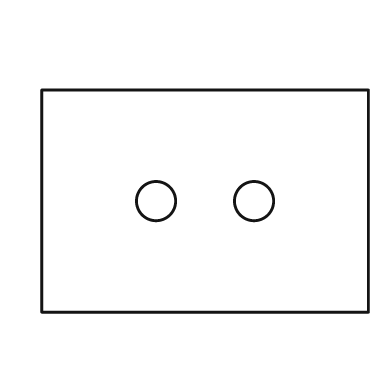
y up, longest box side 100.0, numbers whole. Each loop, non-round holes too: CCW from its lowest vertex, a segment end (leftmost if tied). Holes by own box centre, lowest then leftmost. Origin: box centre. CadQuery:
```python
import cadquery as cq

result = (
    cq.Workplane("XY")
    .moveTo(-50.0, -34.0)
    .lineTo(50.0, -34.0)
    .lineTo(50.0, 34.0)
    .lineTo(-50.0, 34.0)
    .close()
    .moveTo(-15.0, 0.0)
    .circle(6.0)
    .moveTo(15.0, 0.0)
    .circle(6.0)
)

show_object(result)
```